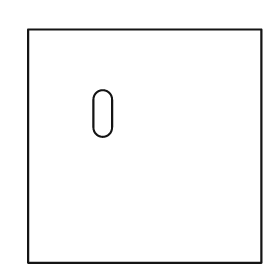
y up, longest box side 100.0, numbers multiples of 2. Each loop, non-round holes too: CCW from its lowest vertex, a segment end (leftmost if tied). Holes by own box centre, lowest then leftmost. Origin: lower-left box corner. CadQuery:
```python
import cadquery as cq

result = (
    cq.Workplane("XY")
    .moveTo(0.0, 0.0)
    .lineTo(100.0, 0.0)
    .lineTo(100.0, 100.0)
    .lineTo(0.0, 100.0)
    .close()
    .moveTo(28.0, 58.0)
    .threePointArc((32.0, 54.0), (36.0, 58.0))
    .lineTo(36.0, 70.0)
    .threePointArc((32.0, 74.0), (28.0, 70.0))
    .close()
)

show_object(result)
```